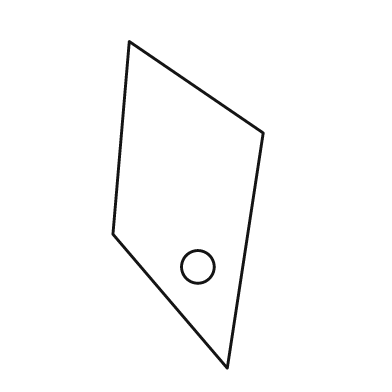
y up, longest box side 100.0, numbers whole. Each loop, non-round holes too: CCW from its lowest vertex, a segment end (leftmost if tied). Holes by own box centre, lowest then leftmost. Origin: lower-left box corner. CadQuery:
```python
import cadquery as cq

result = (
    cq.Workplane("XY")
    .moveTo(35.0, 0.0)
    .lineTo(46.0, 72.0)
    .lineTo(5.0, 100.0)
    .lineTo(0.0, 41.0)
    .close()
    .moveTo(26.0, 31.0)
    .circle(5.0)
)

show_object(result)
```